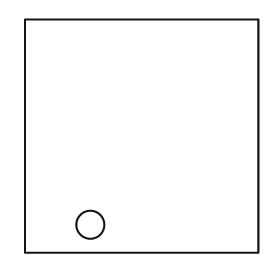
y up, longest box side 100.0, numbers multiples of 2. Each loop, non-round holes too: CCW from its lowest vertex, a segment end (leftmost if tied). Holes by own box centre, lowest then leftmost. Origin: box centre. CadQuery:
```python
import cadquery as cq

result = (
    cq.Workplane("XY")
    .moveTo(-50.0, -50.0)
    .lineTo(50.0, -50.0)
    .lineTo(50.0, 50.0)
    .lineTo(-50.0, 50.0)
    .close()
    .moveTo(-22.0, -38.0)
    .circle(6.0)
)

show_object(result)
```